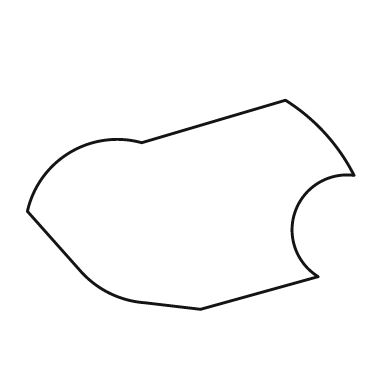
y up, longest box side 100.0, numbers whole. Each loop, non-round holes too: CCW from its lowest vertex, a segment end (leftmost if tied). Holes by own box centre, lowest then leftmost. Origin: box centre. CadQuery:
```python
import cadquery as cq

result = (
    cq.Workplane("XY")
    .moveTo(3.0, -32.0)
    .lineTo(39.0, -22.0)
    .threePointArc((32.0, -2.0), (50.0, 9.0))
    .threePointArc((41.0, 22.0), (29.0, 32.0))
    .lineTo(-15.0, 19.0)
    .threePointArc((-37.0, 16.0), (-50.0, -2.0))
    .lineTo(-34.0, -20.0)
    .threePointArc((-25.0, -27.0), (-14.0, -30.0))
    .close()
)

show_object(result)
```